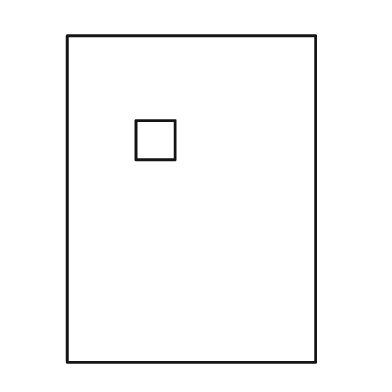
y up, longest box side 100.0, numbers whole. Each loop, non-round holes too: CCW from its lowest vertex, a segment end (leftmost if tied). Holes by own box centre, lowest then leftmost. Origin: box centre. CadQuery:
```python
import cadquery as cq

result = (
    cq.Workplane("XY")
    .moveTo(-38.0, -50.0)
    .lineTo(38.0, -50.0)
    .lineTo(38.0, 50.0)
    .lineTo(-38.0, 50.0)
    .close()
    .moveTo(-17.0, 12.0)
    .lineTo(-5.0, 12.0)
    .lineTo(-5.0, 24.0)
    .lineTo(-17.0, 24.0)
    .close()
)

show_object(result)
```